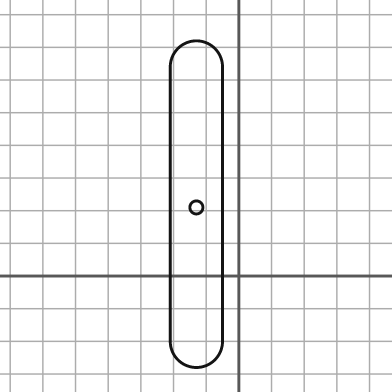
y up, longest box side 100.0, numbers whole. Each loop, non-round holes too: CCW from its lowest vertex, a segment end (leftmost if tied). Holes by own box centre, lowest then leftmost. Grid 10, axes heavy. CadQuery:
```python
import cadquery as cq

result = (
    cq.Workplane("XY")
    .moveTo(-21.0, -20.0)
    .threePointArc((-13.0, -28.0), (-5.0, -20.0))
    .lineTo(-5.0, 64.0)
    .threePointArc((-13.0, 72.0), (-21.0, 64.0))
    .close()
    .moveTo(-13.0, 21.0)
    .circle(2.0)
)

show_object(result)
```